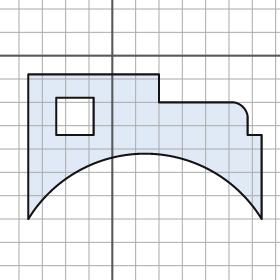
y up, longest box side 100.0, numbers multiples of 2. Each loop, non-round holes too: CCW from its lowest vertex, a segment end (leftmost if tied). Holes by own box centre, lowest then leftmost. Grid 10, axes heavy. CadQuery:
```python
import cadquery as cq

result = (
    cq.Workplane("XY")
    .moveTo(-36.0, -70.0)
    .threePointArc((14.0, -42.0), (64.0, -70.0))
    .lineTo(64.0, -34.0)
    .lineTo(58.0, -34.0)
    .lineTo(58.0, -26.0)
    .threePointArc((56.0, -22.0), (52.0, -20.0))
    .lineTo(20.0, -20.0)
    .lineTo(20.0, -8.0)
    .lineTo(-36.0, -8.0)
    .close()
    .moveTo(-24.0, -34.0)
    .lineTo(-8.0, -34.0)
    .lineTo(-8.0, -18.0)
    .lineTo(-24.0, -18.0)
    .close()
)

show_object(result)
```